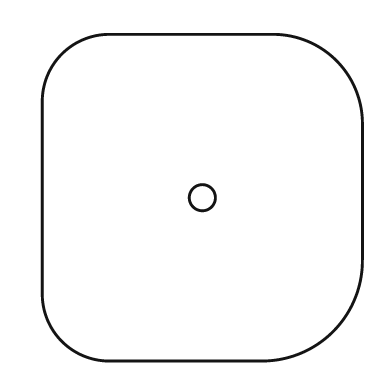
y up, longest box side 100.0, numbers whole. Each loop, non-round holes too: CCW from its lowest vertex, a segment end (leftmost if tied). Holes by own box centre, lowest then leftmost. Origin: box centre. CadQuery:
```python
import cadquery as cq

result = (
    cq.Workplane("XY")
    .moveTo(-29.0, -50.0)
    .lineTo(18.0, -50.0)
    .threePointArc((40.0, -41.0), (49.0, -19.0))
    .lineTo(49.0, 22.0)
    .threePointArc((41.0, 42.0), (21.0, 50.0))
    .lineTo(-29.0, 50.0)
    .threePointArc((-43.0, 44.0), (-49.0, 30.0))
    .lineTo(-49.0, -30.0)
    .threePointArc((-43.0, -44.0), (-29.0, -50.0))
    .close()
    .moveTo(0.0, 0.0)
    .circle(4.0)
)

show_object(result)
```